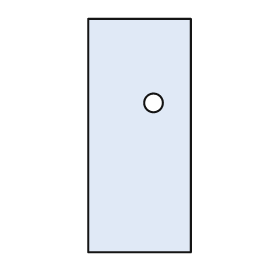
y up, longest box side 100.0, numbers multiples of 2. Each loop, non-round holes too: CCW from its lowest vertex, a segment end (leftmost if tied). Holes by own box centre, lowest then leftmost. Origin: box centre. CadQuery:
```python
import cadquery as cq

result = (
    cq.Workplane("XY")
    .moveTo(-22.0, -50.0)
    .lineTo(22.0, -50.0)
    .lineTo(22.0, 50.0)
    .lineTo(-22.0, 50.0)
    .close()
    .moveTo(6.0, 14.0)
    .circle(4.0)
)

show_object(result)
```